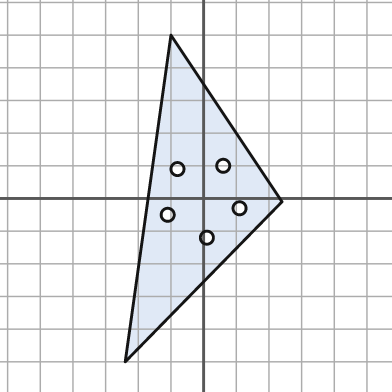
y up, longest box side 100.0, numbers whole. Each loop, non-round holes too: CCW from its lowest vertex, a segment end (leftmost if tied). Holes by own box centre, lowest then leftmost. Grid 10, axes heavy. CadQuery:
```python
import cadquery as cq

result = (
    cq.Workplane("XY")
    .moveTo(-24.0, -50.0)
    .lineTo(24.0, -1.0)
    .lineTo(-10.0, 50.0)
    .close()
    .moveTo(1.0, -12.0)
    .circle(2.0)
    .moveTo(-11.0, -5.0)
    .circle(2.0)
    .moveTo(11.0, -3.0)
    .circle(2.0)
    .moveTo(-8.0, 9.0)
    .circle(2.0)
    .moveTo(6.0, 10.0)
    .circle(2.0)
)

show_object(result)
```